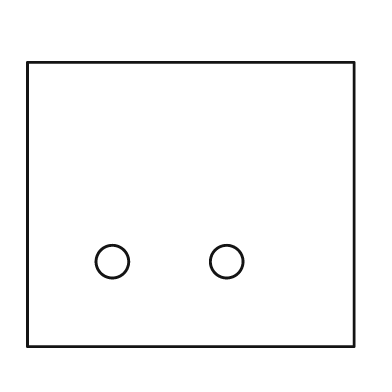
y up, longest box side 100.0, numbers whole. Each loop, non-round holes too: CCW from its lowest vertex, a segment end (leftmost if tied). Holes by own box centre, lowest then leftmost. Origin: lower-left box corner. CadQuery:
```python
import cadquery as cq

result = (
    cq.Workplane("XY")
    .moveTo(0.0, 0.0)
    .lineTo(100.0, 0.0)
    .lineTo(100.0, 87.0)
    .lineTo(0.0, 87.0)
    .close()
    .moveTo(26.0, 26.0)
    .circle(5.0)
    .moveTo(61.0, 26.0)
    .circle(5.0)
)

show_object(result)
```